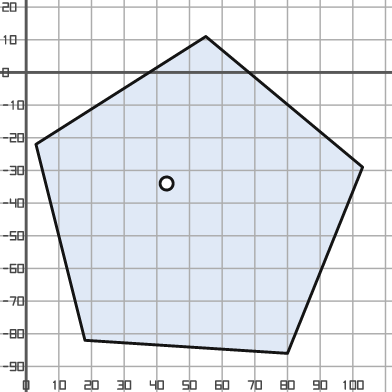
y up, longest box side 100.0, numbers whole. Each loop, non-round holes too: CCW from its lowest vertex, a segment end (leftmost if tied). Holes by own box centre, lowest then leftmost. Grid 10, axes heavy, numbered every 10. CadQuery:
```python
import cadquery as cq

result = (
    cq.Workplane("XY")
    .moveTo(80.0, -86.0)
    .lineTo(103.0, -29.0)
    .lineTo(55.0, 11.0)
    .lineTo(3.0, -22.0)
    .lineTo(18.0, -82.0)
    .close()
    .moveTo(43.0, -34.0)
    .circle(2.0)
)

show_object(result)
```